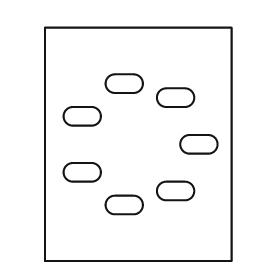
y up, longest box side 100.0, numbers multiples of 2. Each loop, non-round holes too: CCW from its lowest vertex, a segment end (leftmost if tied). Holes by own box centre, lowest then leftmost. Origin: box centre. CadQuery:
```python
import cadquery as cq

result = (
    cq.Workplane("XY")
    .moveTo(-40.0, -50.0)
    .lineTo(40.0, -50.0)
    .lineTo(40.0, 50.0)
    .lineTo(-40.0, 50.0)
    .close()
    .moveTo(-10.0, -30.0)
    .lineTo(-2.0, -30.0)
    .threePointArc((2.0, -26.0), (-2.0, -22.0))
    .lineTo(-10.0, -22.0)
    .threePointArc((-14.0, -26.0), (-10.0, -30.0))
    .close()
    .moveTo(12.0, -24.0)
    .lineTo(20.0, -24.0)
    .threePointArc((24.0, -20.0), (20.0, -16.0))
    .lineTo(12.0, -16.0)
    .threePointArc((8.0, -20.0), (12.0, -24.0))
    .close()
    .moveTo(-28.0, -16.0)
    .lineTo(-20.0, -16.0)
    .threePointArc((-16.0, -12.0), (-20.0, -8.0))
    .lineTo(-28.0, -8.0)
    .threePointArc((-32.0, -12.0), (-28.0, -16.0))
    .close()
    .moveTo(22.0, -4.0)
    .lineTo(30.0, -4.0)
    .threePointArc((34.0, 0.0), (30.0, 4.0))
    .lineTo(22.0, 4.0)
    .threePointArc((18.0, 0.0), (22.0, -4.0))
    .close()
    .moveTo(-28.0, 8.0)
    .lineTo(-20.0, 8.0)
    .threePointArc((-16.0, 12.0), (-20.0, 16.0))
    .lineTo(-28.0, 16.0)
    .threePointArc((-32.0, 12.0), (-28.0, 8.0))
    .close()
    .moveTo(12.0, 16.0)
    .lineTo(20.0, 16.0)
    .threePointArc((24.0, 20.0), (20.0, 24.0))
    .lineTo(12.0, 24.0)
    .threePointArc((8.0, 20.0), (12.0, 16.0))
    .close()
    .moveTo(-10.0, 22.0)
    .lineTo(-2.0, 22.0)
    .threePointArc((2.0, 26.0), (-2.0, 30.0))
    .lineTo(-10.0, 30.0)
    .threePointArc((-14.0, 26.0), (-10.0, 22.0))
    .close()
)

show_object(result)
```